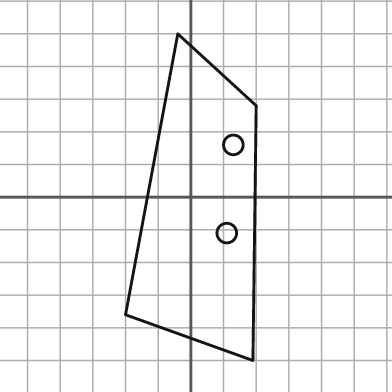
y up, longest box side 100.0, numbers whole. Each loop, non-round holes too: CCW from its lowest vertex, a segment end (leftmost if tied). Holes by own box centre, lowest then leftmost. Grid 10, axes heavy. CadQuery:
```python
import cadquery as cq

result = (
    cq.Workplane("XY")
    .moveTo(19.0, -50.0)
    .lineTo(20.0, 28.0)
    .lineTo(-4.0, 50.0)
    .lineTo(-20.0, -36.0)
    .close()
    .moveTo(11.0, -11.0)
    .circle(3.0)
    .moveTo(13.0, 16.0)
    .circle(3.0)
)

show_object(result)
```